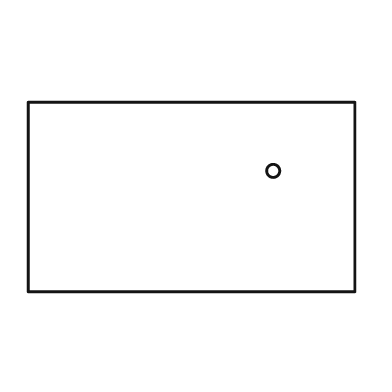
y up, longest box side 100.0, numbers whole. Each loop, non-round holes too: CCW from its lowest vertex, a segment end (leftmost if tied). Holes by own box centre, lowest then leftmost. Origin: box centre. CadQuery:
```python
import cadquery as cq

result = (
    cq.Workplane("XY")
    .moveTo(-50.0, -29.0)
    .lineTo(50.0, -29.0)
    .lineTo(50.0, 29.0)
    .lineTo(-50.0, 29.0)
    .close()
    .moveTo(25.0, 8.0)
    .circle(2.0)
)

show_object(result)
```